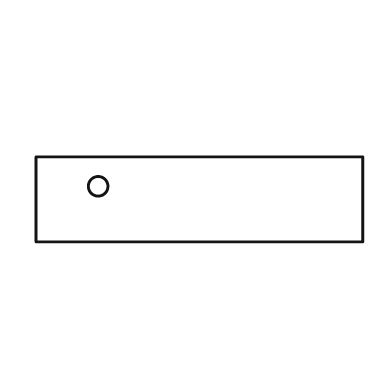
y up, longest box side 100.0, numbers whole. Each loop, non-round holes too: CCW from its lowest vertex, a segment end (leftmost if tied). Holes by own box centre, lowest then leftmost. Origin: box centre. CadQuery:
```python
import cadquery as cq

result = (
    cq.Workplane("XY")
    .moveTo(-50.0, -13.0)
    .lineTo(50.0, -13.0)
    .lineTo(50.0, 13.0)
    .lineTo(-50.0, 13.0)
    .close()
    .moveTo(-31.0, 4.0)
    .circle(3.0)
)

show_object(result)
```